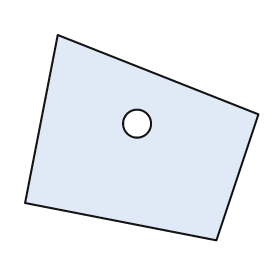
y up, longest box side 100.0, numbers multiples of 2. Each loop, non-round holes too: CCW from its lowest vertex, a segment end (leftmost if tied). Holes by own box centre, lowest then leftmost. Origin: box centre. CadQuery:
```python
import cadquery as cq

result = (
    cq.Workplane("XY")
    .moveTo(32.0, -44.0)
    .lineTo(50.0, 10.0)
    .lineTo(-36.0, 44.0)
    .lineTo(-50.0, -28.0)
    .close()
    .moveTo(-2.0, 6.0)
    .circle(6.0)
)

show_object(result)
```